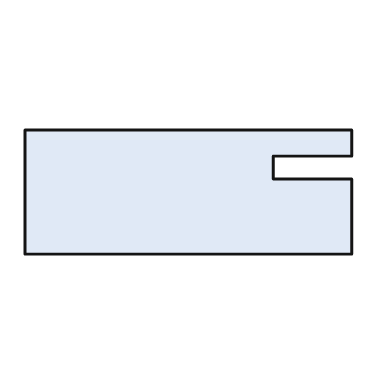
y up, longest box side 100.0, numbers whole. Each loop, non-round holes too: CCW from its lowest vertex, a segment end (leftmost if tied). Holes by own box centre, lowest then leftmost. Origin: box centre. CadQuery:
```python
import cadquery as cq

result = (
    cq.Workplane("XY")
    .moveTo(-50.0, -19.0)
    .lineTo(50.0, -19.0)
    .lineTo(50.0, 4.0)
    .lineTo(26.0, 4.0)
    .lineTo(26.0, 11.0)
    .lineTo(50.0, 11.0)
    .lineTo(50.0, 19.0)
    .lineTo(-50.0, 19.0)
    .close()
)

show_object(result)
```